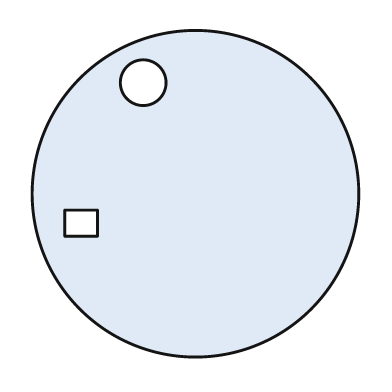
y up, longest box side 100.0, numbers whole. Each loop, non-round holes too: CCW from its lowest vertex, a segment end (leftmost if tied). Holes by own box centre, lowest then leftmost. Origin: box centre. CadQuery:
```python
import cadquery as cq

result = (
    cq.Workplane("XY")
    .moveTo(0.0, 0.0)
    .circle(50.0)
    .moveTo(-40.0, -13.0)
    .lineTo(-30.0, -13.0)
    .lineTo(-30.0, -5.0)
    .lineTo(-40.0, -5.0)
    .close()
    .moveTo(-16.0, 34.0)
    .circle(7.0)
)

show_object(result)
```